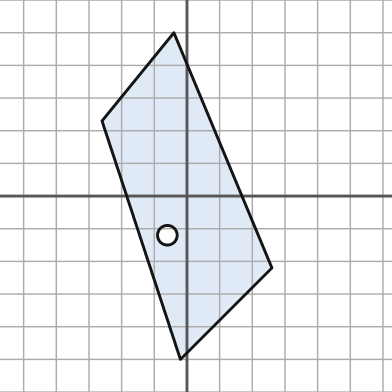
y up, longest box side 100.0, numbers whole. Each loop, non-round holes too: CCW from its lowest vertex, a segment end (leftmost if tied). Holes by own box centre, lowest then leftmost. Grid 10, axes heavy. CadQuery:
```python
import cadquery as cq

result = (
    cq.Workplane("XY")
    .moveTo(-2.0, -50.0)
    .lineTo(26.0, -22.0)
    .lineTo(-4.0, 50.0)
    .lineTo(-26.0, 23.0)
    .close()
    .moveTo(-6.0, -12.0)
    .circle(3.0)
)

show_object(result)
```